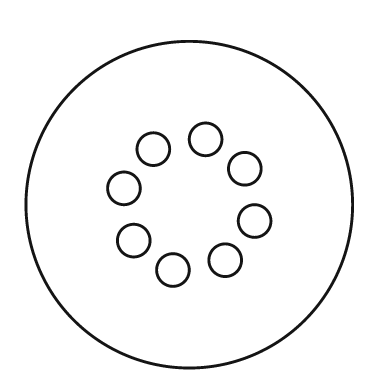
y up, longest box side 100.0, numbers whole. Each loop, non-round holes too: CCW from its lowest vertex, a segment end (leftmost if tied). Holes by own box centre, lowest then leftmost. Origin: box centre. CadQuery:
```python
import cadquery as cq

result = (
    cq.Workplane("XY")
    .moveTo(0.0, 0.0)
    .circle(50.0)
    .moveTo(-5.0, -20.0)
    .circle(5.0)
    .moveTo(11.0, -17.0)
    .circle(5.0)
    .moveTo(-17.0, -11.0)
    .circle(5.0)
    .moveTo(20.0, -5.0)
    .circle(5.0)
    .moveTo(-20.0, 5.0)
    .circle(5.0)
    .moveTo(17.0, 11.0)
    .circle(5.0)
    .moveTo(-11.0, 17.0)
    .circle(5.0)
    .moveTo(5.0, 20.0)
    .circle(5.0)
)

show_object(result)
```